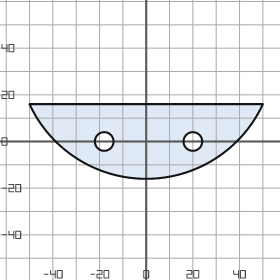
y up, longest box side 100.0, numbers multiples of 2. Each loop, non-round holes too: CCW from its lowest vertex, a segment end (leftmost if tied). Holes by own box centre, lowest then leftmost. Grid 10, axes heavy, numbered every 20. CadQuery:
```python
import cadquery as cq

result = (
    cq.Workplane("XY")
    .moveTo(-50.0, 16.0)
    .threePointArc((0.0, -16.0), (50.0, 16.0))
    .close()
    .moveTo(-18.0, 0.0)
    .circle(4.0)
    .moveTo(20.0, 0.0)
    .circle(4.0)
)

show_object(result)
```